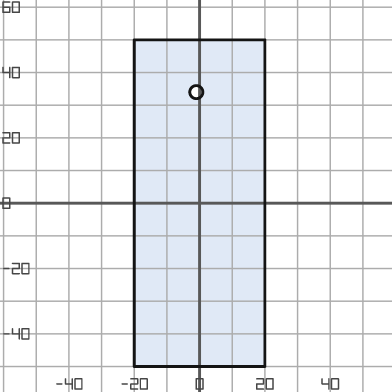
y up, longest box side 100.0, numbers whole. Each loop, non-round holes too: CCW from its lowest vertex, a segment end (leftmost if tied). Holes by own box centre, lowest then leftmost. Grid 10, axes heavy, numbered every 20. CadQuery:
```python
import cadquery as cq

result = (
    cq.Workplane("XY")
    .moveTo(-20.0, -50.0)
    .lineTo(20.0, -50.0)
    .lineTo(20.0, 50.0)
    .lineTo(-20.0, 50.0)
    .close()
    .moveTo(-1.0, 34.0)
    .circle(2.0)
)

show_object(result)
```